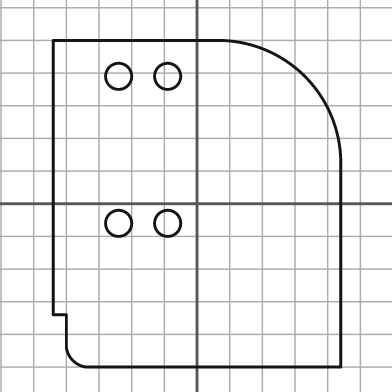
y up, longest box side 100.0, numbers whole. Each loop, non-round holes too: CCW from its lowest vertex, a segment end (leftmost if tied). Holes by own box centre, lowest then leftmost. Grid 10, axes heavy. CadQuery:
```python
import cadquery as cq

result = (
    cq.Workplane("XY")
    .moveTo(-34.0, -50.0)
    .lineTo(44.0, -50.0)
    .lineTo(44.0, 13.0)
    .threePointArc((33.0, 39.0), (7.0, 50.0))
    .lineTo(-44.0, 50.0)
    .lineTo(-44.0, -34.0)
    .lineTo(-40.0, -34.0)
    .lineTo(-40.0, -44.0)
    .threePointArc((-38.0, -48.0), (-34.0, -50.0))
    .close()
    .moveTo(-24.0, -6.0)
    .circle(4.0)
    .moveTo(-9.0, -6.0)
    .circle(4.0)
    .moveTo(-24.0, 39.0)
    .circle(4.0)
    .moveTo(-9.0, 39.0)
    .circle(4.0)
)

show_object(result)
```